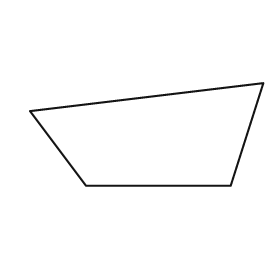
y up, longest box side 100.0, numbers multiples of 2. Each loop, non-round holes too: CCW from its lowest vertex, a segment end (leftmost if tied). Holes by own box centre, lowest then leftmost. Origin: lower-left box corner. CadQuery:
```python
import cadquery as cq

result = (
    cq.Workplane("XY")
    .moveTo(24.0, 0.0)
    .lineTo(86.0, 0.0)
    .lineTo(100.0, 44.0)
    .lineTo(0.0, 32.0)
    .close()
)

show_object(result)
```